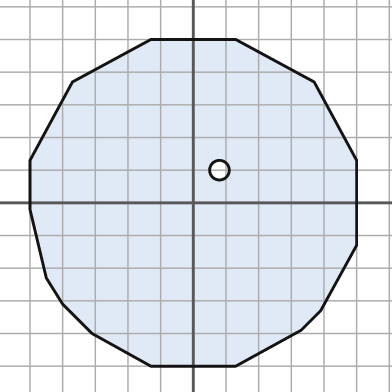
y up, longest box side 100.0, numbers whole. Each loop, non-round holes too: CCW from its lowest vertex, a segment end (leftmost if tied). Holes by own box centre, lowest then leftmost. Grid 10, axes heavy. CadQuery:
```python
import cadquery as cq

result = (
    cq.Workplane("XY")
    .moveTo(-13.0, -50.0)
    .lineTo(13.0, -50.0)
    .lineTo(33.0, -39.0)
    .lineTo(39.0, -33.0)
    .lineTo(50.0, -13.0)
    .lineTo(50.0, 13.0)
    .lineTo(37.0, 37.0)
    .lineTo(13.0, 50.0)
    .lineTo(-13.0, 50.0)
    .lineTo(-37.0, 37.0)
    .lineTo(-50.0, 13.0)
    .lineTo(-50.0, -2.0)
    .lineTo(-45.0, -23.0)
    .lineTo(-40.0, -31.0)
    .lineTo(-31.0, -40.0)
    .close()
    .moveTo(8.0, 10.0)
    .circle(3.0)
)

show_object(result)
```